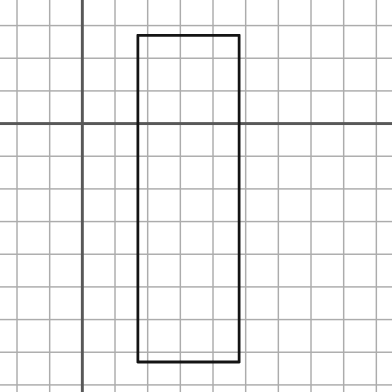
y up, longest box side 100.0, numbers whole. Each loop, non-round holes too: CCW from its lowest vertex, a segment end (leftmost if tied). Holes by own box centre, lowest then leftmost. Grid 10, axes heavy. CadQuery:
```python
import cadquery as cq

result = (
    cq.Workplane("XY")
    .moveTo(17.0, -73.0)
    .lineTo(48.0, -73.0)
    .lineTo(48.0, 27.0)
    .lineTo(17.0, 27.0)
    .close()
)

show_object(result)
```